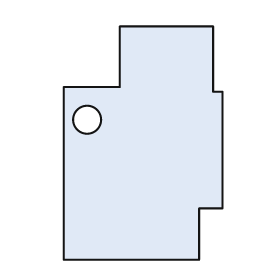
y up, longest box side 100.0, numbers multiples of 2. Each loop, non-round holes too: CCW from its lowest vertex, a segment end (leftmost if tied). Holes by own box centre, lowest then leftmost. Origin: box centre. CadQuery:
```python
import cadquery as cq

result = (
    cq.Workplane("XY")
    .moveTo(-34.0, -50.0)
    .lineTo(24.0, -50.0)
    .lineTo(24.0, -28.0)
    .lineTo(34.0, -28.0)
    .lineTo(34.0, 22.0)
    .lineTo(30.0, 22.0)
    .lineTo(30.0, 50.0)
    .lineTo(-10.0, 50.0)
    .lineTo(-10.0, 24.0)
    .lineTo(-34.0, 24.0)
    .close()
    .moveTo(-24.0, 10.0)
    .circle(6.0)
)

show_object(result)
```